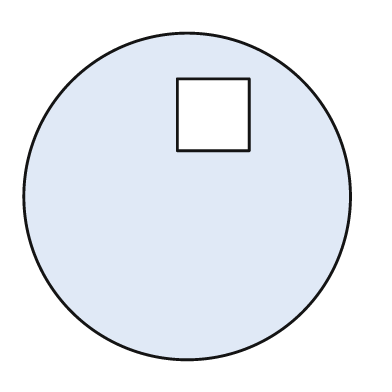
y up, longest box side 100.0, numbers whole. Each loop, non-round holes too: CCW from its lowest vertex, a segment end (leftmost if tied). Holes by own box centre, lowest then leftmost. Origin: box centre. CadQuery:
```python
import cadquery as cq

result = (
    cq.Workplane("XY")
    .moveTo(0.0, 0.0)
    .circle(50.0)
    .moveTo(-3.0, 14.0)
    .lineTo(19.0, 14.0)
    .lineTo(19.0, 36.0)
    .lineTo(-3.0, 36.0)
    .close()
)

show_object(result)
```